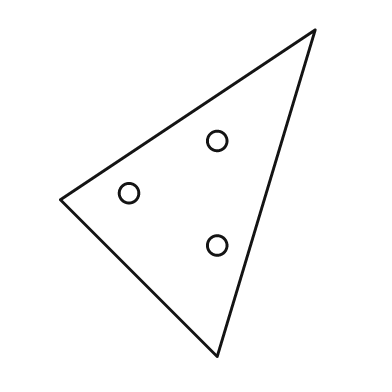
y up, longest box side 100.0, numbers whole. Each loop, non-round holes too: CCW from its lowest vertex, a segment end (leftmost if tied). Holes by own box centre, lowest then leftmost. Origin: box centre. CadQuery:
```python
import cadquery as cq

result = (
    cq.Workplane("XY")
    .moveTo(9.0, -50.0)
    .lineTo(39.0, 50.0)
    .lineTo(-39.0, -2.0)
    .close()
    .moveTo(9.0, -16.0)
    .circle(3.0)
    .moveTo(-18.0, 0.0)
    .circle(3.0)
    .moveTo(9.0, 16.0)
    .circle(3.0)
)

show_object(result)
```